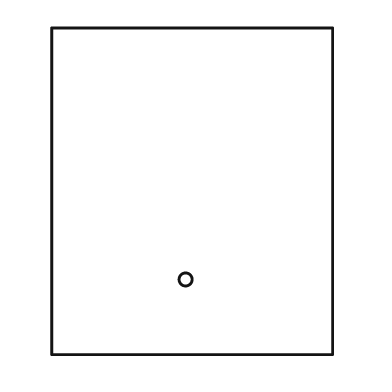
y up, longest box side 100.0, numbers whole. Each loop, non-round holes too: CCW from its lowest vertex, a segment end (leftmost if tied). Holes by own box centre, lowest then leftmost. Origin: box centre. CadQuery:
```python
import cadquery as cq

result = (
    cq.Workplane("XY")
    .moveTo(-43.0, -50.0)
    .lineTo(43.0, -50.0)
    .lineTo(43.0, 50.0)
    .lineTo(-43.0, 50.0)
    .close()
    .moveTo(-2.0, -27.0)
    .circle(2.0)
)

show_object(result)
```